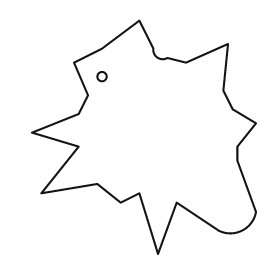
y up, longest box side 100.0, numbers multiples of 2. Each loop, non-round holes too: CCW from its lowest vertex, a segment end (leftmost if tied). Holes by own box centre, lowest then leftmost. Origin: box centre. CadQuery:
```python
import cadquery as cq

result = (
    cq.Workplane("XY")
    .moveTo(6.0, -50.0)
    .lineTo(14.0, -28.0)
    .lineTo(32.0, -40.0)
    .threePointArc((42.0, -40.0), (48.0, -32.0))
    .lineTo(40.0, -10.0)
    .lineTo(40.0, -4.0)
    .lineTo(48.0, 6.0)
    .lineTo(38.0, 12.0)
    .lineTo(34.0, 20.0)
    .lineTo(36.0, 40.0)
    .lineTo(18.0, 32.0)
    .lineTo(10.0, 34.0)
    .threePointArc((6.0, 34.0), (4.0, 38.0))
    .lineTo(-2.0, 50.0)
    .lineTo(-18.0, 38.0)
    .lineTo(-30.0, 32.0)
    .lineTo(-24.0, 18.0)
    .lineTo(-28.0, 10.0)
    .lineTo(-48.0, 2.0)
    .lineTo(-28.0, -4.0)
    .lineTo(-44.0, -24.0)
    .lineTo(-20.0, -20.0)
    .lineTo(-10.0, -28.0)
    .lineTo(-2.0, -24.0)
    .close()
    .moveTo(-18.0, 26.0)
    .circle(2.0)
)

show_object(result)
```